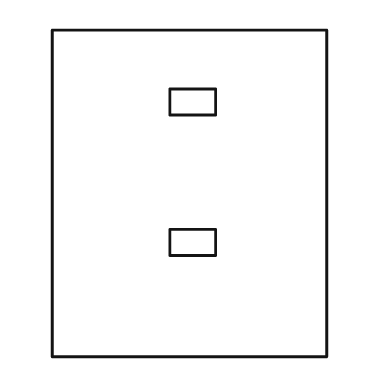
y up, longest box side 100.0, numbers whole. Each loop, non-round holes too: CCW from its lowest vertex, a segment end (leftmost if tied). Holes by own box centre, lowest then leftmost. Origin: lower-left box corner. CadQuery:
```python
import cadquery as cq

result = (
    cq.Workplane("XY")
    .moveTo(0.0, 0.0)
    .lineTo(84.0, 0.0)
    .lineTo(84.0, 100.0)
    .lineTo(0.0, 100.0)
    .close()
    .moveTo(36.0, 31.0)
    .lineTo(50.0, 31.0)
    .lineTo(50.0, 39.0)
    .lineTo(36.0, 39.0)
    .close()
    .moveTo(36.0, 74.0)
    .lineTo(50.0, 74.0)
    .lineTo(50.0, 82.0)
    .lineTo(36.0, 82.0)
    .close()
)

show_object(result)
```